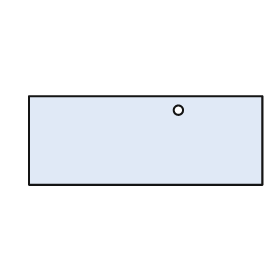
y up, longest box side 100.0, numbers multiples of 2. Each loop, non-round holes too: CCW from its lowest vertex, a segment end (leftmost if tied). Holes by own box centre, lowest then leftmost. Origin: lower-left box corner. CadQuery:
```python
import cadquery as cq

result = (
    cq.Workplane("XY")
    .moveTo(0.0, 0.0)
    .lineTo(100.0, 0.0)
    .lineTo(100.0, 38.0)
    .lineTo(0.0, 38.0)
    .close()
    .moveTo(64.0, 32.0)
    .circle(2.0)
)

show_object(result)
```